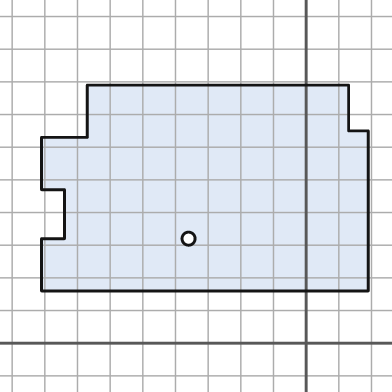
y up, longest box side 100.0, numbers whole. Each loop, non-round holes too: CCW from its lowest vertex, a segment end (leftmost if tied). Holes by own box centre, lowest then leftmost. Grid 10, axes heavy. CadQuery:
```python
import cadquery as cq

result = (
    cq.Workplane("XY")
    .moveTo(-81.0, 16.0)
    .lineTo(19.0, 16.0)
    .lineTo(19.0, 65.0)
    .lineTo(13.0, 65.0)
    .lineTo(13.0, 79.0)
    .lineTo(-67.0, 79.0)
    .lineTo(-67.0, 63.0)
    .lineTo(-81.0, 63.0)
    .lineTo(-81.0, 47.0)
    .lineTo(-74.0, 47.0)
    .lineTo(-74.0, 32.0)
    .lineTo(-81.0, 32.0)
    .close()
    .moveTo(-36.0, 32.0)
    .circle(2.0)
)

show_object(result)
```